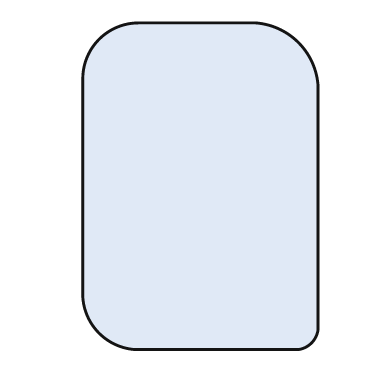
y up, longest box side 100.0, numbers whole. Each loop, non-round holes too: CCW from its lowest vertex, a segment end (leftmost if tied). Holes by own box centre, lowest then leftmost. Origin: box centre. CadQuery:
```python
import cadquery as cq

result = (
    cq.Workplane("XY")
    .moveTo(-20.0, -50.0)
    .lineTo(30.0, -50.0)
    .threePointArc((34.0, -48.0), (36.0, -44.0))
    .lineTo(36.0, 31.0)
    .threePointArc((30.0, 44.0), (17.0, 50.0))
    .lineTo(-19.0, 50.0)
    .threePointArc((-31.0, 45.0), (-36.0, 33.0))
    .lineTo(-36.0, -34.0)
    .threePointArc((-31.0, -45.0), (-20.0, -50.0))
    .close()
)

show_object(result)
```